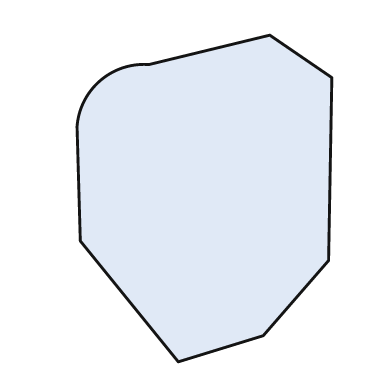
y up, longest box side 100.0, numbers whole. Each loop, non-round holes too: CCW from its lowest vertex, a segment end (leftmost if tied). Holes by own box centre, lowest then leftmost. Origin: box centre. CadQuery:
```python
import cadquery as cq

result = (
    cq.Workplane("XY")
    .moveTo(-8.0, -50.0)
    .lineTo(18.0, -42.0)
    .lineTo(38.0, -19.0)
    .lineTo(39.0, 37.0)
    .lineTo(20.0, 50.0)
    .lineTo(-17.0, 41.0)
    .threePointArc((-32.0, 36.0), (-39.0, 22.0))
    .lineTo(-38.0, -13.0)
    .close()
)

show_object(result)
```